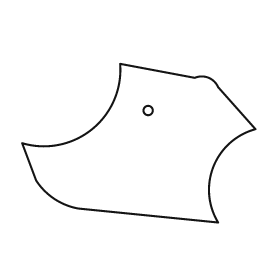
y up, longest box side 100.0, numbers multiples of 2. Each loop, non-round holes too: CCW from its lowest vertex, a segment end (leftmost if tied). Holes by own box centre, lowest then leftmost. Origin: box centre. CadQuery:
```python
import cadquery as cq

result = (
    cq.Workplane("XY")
    .moveTo(34.0, -34.0)
    .threePointArc((32.0, -10.0), (50.0, 6.0))
    .lineTo(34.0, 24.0)
    .threePointArc((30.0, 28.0), (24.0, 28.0))
    .lineTo(-8.0, 34.0)
    .threePointArc((-20.0, 6.0), (-50.0, 0.0))
    .lineTo(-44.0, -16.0)
    .threePointArc((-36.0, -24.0), (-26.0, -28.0))
    .close()
    .moveTo(4.0, 14.0)
    .circle(2.0)
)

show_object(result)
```